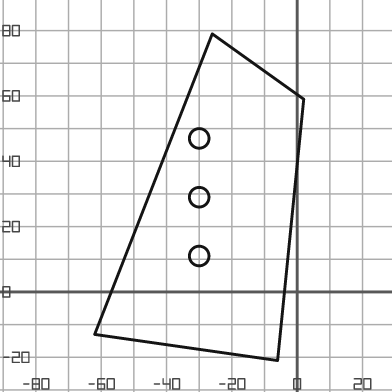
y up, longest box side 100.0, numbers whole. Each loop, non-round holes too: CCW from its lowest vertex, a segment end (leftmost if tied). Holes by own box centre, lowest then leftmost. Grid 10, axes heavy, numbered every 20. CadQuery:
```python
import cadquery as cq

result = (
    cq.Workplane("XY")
    .moveTo(-6.0, -21.0)
    .lineTo(2.0, 59.0)
    .lineTo(-26.0, 79.0)
    .lineTo(-62.0, -13.0)
    .close()
    .moveTo(-30.0, 11.0)
    .circle(3.0)
    .moveTo(-30.0, 29.0)
    .circle(3.0)
    .moveTo(-30.0, 47.0)
    .circle(3.0)
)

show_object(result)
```